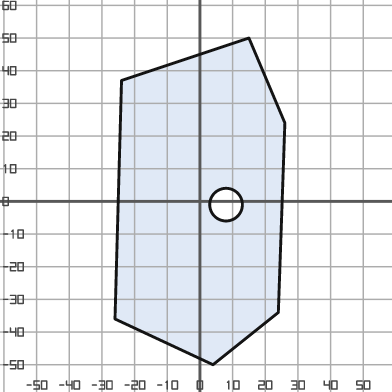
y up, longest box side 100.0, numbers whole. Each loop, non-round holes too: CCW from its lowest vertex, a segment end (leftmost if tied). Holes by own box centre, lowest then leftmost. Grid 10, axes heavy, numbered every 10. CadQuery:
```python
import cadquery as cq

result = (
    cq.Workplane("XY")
    .moveTo(4.0, -50.0)
    .lineTo(24.0, -34.0)
    .lineTo(26.0, 24.0)
    .lineTo(15.0, 50.0)
    .lineTo(-24.0, 37.0)
    .lineTo(-26.0, -36.0)
    .close()
    .moveTo(8.0, -1.0)
    .circle(5.0)
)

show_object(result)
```